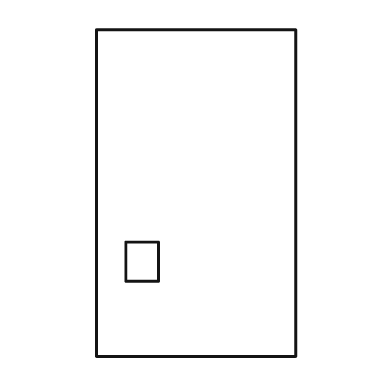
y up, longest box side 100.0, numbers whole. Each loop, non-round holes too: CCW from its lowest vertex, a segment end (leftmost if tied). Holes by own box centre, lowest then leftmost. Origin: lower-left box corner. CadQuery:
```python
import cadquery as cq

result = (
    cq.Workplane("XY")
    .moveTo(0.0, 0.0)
    .lineTo(61.0, 0.0)
    .lineTo(61.0, 100.0)
    .lineTo(0.0, 100.0)
    .close()
    .moveTo(9.0, 23.0)
    .lineTo(19.0, 23.0)
    .lineTo(19.0, 35.0)
    .lineTo(9.0, 35.0)
    .close()
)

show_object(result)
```